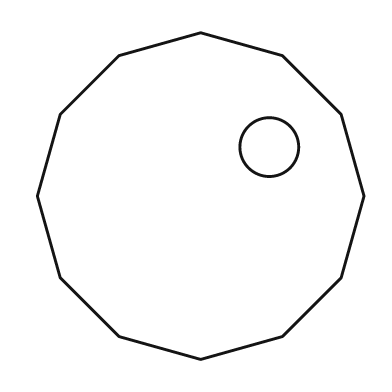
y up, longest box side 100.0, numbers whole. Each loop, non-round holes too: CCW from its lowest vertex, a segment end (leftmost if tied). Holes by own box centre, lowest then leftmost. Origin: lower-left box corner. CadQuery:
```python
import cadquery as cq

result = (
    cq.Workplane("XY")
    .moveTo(50.0, 0.0)
    .lineTo(75.0, 7.0)
    .lineTo(93.0, 25.0)
    .lineTo(100.0, 50.0)
    .lineTo(93.0, 75.0)
    .lineTo(75.0, 93.0)
    .lineTo(50.0, 100.0)
    .lineTo(25.0, 93.0)
    .lineTo(7.0, 75.0)
    .lineTo(0.0, 50.0)
    .lineTo(7.0, 25.0)
    .lineTo(25.0, 7.0)
    .close()
    .moveTo(71.0, 65.0)
    .circle(9.0)
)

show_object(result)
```